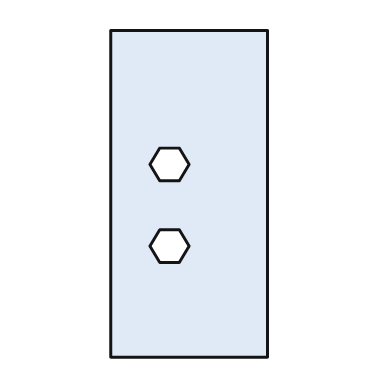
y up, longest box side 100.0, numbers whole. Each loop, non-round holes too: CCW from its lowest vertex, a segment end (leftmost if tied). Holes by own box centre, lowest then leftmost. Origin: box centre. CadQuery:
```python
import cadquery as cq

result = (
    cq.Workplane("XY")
    .moveTo(-24.0, -50.0)
    .lineTo(24.0, -50.0)
    .lineTo(24.0, 50.0)
    .lineTo(-24.0, 50.0)
    .close()
    .moveTo(-9.0, -21.0)
    .lineTo(-3.0, -21.0)
    .lineTo(0.0, -16.0)
    .lineTo(-3.0, -11.0)
    .lineTo(-9.0, -11.0)
    .lineTo(-12.0, -16.0)
    .close()
    .moveTo(-9.0, 4.0)
    .lineTo(-3.0, 4.0)
    .lineTo(0.0, 9.0)
    .lineTo(-3.0, 14.0)
    .lineTo(-9.0, 14.0)
    .lineTo(-12.0, 9.0)
    .close()
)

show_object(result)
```